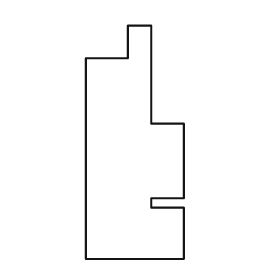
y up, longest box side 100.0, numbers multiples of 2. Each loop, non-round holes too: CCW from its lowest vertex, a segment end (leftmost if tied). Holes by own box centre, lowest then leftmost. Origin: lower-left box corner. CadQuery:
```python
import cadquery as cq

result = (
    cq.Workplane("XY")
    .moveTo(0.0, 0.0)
    .lineTo(42.0, 0.0)
    .lineTo(42.0, 22.0)
    .lineTo(28.0, 22.0)
    .lineTo(28.0, 26.0)
    .lineTo(42.0, 26.0)
    .lineTo(42.0, 58.0)
    .lineTo(28.0, 58.0)
    .lineTo(28.0, 100.0)
    .lineTo(18.0, 100.0)
    .lineTo(18.0, 86.0)
    .lineTo(0.0, 86.0)
    .close()
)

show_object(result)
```